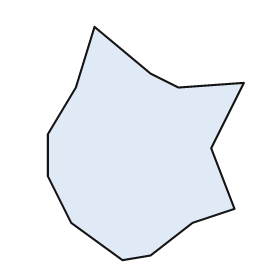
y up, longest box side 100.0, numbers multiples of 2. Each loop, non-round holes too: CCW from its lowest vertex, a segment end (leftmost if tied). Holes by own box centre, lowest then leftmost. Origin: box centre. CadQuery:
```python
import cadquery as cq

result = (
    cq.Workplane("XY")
    .moveTo(-10.0, -50.0)
    .lineTo(2.0, -48.0)
    .lineTo(20.0, -34.0)
    .lineTo(38.0, -28.0)
    .lineTo(28.0, -2.0)
    .lineTo(42.0, 26.0)
    .lineTo(14.0, 24.0)
    .lineTo(2.0, 30.0)
    .lineTo(-22.0, 50.0)
    .lineTo(-30.0, 24.0)
    .lineTo(-42.0, 4.0)
    .lineTo(-42.0, -14.0)
    .lineTo(-32.0, -34.0)
    .close()
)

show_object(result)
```